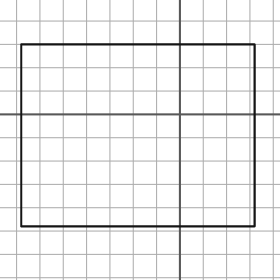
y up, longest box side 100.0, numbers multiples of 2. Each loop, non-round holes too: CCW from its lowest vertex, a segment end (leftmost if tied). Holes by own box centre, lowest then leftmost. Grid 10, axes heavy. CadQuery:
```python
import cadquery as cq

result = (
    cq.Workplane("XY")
    .moveTo(-68.0, -48.0)
    .lineTo(32.0, -48.0)
    .lineTo(32.0, 30.0)
    .lineTo(-68.0, 30.0)
    .close()
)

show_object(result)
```